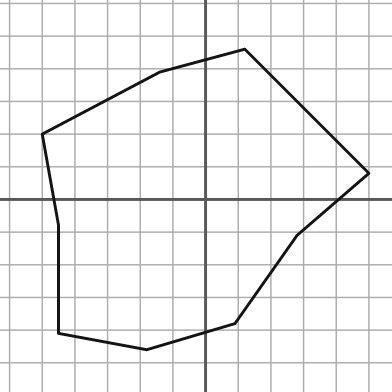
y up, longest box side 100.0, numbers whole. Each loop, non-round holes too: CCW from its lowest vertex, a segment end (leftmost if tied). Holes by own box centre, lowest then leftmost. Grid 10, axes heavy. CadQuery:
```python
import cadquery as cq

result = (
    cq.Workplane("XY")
    .moveTo(-18.0, -46.0)
    .lineTo(9.0, -38.0)
    .lineTo(28.0, -11.0)
    .lineTo(50.0, 8.0)
    .lineTo(12.0, 46.0)
    .lineTo(-14.0, 39.0)
    .lineTo(-50.0, 20.0)
    .lineTo(-45.0, -8.0)
    .lineTo(-45.0, -41.0)
    .close()
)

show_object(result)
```